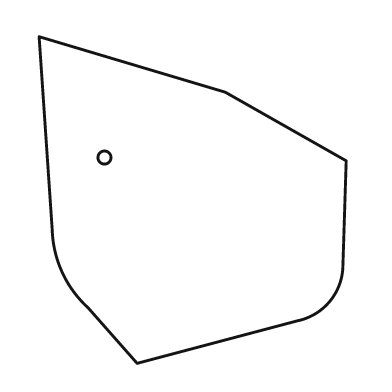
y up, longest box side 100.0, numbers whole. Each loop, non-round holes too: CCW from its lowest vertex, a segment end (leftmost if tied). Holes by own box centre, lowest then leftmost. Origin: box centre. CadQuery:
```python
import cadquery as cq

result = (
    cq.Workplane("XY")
    .moveTo(-17.0, -50.0)
    .lineTo(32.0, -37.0)
    .threePointArc((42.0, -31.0), (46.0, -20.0))
    .lineTo(47.0, 12.0)
    .lineTo(10.0, 33.0)
    .lineTo(-47.0, 50.0)
    .lineTo(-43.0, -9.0)
    .threePointArc((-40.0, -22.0), (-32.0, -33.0))
    .close()
    .moveTo(-27.0, 13.0)
    .circle(2.0)
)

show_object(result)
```